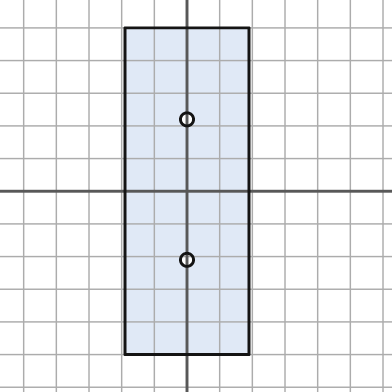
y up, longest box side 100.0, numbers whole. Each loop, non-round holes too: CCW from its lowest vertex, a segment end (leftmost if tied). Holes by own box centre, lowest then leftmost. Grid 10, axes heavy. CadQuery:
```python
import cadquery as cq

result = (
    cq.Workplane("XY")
    .moveTo(-19.0, -50.0)
    .lineTo(19.0, -50.0)
    .lineTo(19.0, 50.0)
    .lineTo(-19.0, 50.0)
    .close()
    .moveTo(0.0, -21.0)
    .circle(2.0)
    .moveTo(0.0, 22.0)
    .circle(2.0)
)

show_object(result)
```